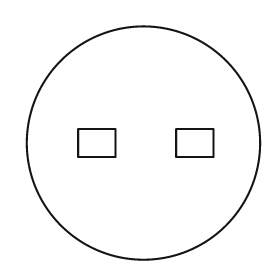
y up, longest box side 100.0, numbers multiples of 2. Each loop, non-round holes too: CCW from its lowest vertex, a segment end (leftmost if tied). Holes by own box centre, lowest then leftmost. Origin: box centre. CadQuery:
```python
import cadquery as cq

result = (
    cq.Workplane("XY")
    .moveTo(0.0, 0.0)
    .circle(50.0)
    .moveTo(-28.0, -6.0)
    .lineTo(-12.0, -6.0)
    .lineTo(-12.0, 6.0)
    .lineTo(-28.0, 6.0)
    .close()
    .moveTo(14.0, -6.0)
    .lineTo(30.0, -6.0)
    .lineTo(30.0, 6.0)
    .lineTo(14.0, 6.0)
    .close()
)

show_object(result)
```